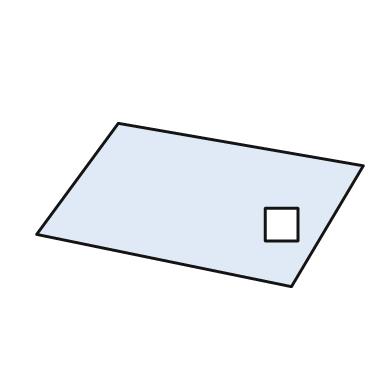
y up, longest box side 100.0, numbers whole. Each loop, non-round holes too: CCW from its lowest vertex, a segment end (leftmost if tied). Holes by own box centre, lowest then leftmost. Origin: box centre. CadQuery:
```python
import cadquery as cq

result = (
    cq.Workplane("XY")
    .moveTo(28.0, -25.0)
    .lineTo(50.0, 12.0)
    .lineTo(-25.0, 25.0)
    .lineTo(-50.0, -9.0)
    .close()
    .moveTo(20.0, -11.0)
    .lineTo(30.0, -11.0)
    .lineTo(30.0, -1.0)
    .lineTo(20.0, -1.0)
    .close()
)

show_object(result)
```